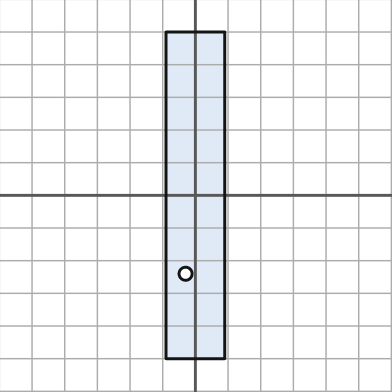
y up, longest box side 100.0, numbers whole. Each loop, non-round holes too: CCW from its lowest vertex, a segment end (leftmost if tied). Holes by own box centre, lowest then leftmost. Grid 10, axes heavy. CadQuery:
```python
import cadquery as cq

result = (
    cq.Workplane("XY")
    .moveTo(-9.0, -50.0)
    .lineTo(9.0, -50.0)
    .lineTo(9.0, 50.0)
    .lineTo(-9.0, 50.0)
    .close()
    .moveTo(-3.0, -24.0)
    .circle(2.0)
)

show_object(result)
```